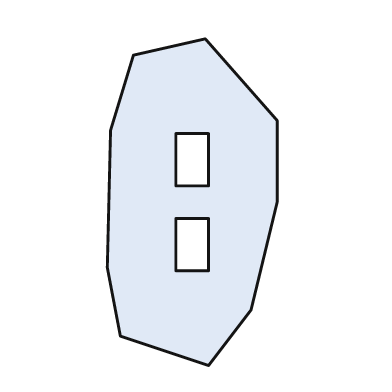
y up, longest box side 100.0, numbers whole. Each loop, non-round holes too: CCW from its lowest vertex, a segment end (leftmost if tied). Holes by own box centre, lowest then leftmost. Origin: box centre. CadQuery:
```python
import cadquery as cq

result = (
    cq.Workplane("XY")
    .moveTo(5.0, -50.0)
    .lineTo(18.0, -33.0)
    .lineTo(26.0, 0.0)
    .lineTo(26.0, 25.0)
    .lineTo(4.0, 50.0)
    .lineTo(-18.0, 45.0)
    .lineTo(-25.0, 22.0)
    .lineTo(-26.0, -20.0)
    .lineTo(-22.0, -41.0)
    .close()
    .moveTo(-5.0, -21.0)
    .lineTo(5.0, -21.0)
    .lineTo(5.0, -5.0)
    .lineTo(-5.0, -5.0)
    .close()
    .moveTo(-5.0, 5.0)
    .lineTo(5.0, 5.0)
    .lineTo(5.0, 21.0)
    .lineTo(-5.0, 21.0)
    .close()
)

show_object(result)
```